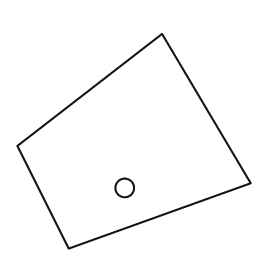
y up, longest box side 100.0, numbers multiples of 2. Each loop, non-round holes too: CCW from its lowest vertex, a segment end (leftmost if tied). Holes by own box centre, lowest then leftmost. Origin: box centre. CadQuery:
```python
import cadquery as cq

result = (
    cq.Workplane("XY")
    .moveTo(-28.0, -46.0)
    .lineTo(50.0, -18.0)
    .lineTo(12.0, 46.0)
    .lineTo(-50.0, -2.0)
    .close()
    .moveTo(-4.0, -20.0)
    .circle(4.0)
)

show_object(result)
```